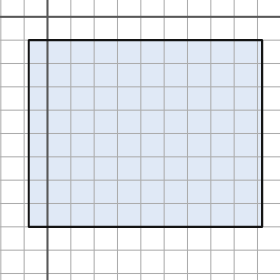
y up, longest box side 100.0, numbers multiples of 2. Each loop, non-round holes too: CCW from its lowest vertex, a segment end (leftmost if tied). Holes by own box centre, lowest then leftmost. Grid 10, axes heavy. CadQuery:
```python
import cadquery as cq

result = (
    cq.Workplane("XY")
    .moveTo(-8.0, -90.0)
    .lineTo(92.0, -90.0)
    .lineTo(92.0, -10.0)
    .lineTo(-8.0, -10.0)
    .close()
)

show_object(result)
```